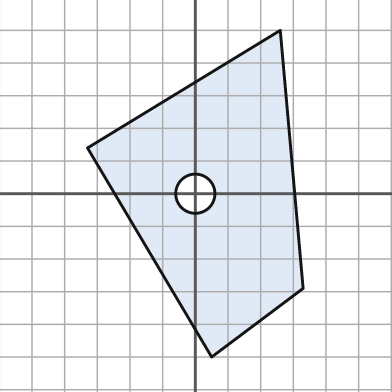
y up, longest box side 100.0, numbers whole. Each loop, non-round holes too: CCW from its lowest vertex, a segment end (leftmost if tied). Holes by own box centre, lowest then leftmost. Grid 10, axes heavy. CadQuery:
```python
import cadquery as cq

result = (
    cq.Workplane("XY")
    .moveTo(5.0, -50.0)
    .lineTo(33.0, -29.0)
    .lineTo(26.0, 50.0)
    .lineTo(-33.0, 14.0)
    .close()
    .moveTo(0.0, 0.0)
    .circle(6.0)
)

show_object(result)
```